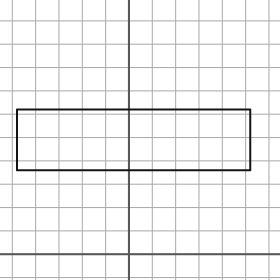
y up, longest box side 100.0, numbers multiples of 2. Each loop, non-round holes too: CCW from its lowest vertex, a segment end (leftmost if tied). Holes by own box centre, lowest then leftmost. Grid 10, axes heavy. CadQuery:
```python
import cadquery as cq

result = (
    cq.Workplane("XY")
    .moveTo(-48.0, 36.0)
    .lineTo(52.0, 36.0)
    .lineTo(52.0, 62.0)
    .lineTo(-48.0, 62.0)
    .close()
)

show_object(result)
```